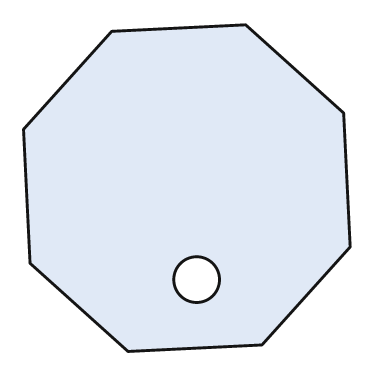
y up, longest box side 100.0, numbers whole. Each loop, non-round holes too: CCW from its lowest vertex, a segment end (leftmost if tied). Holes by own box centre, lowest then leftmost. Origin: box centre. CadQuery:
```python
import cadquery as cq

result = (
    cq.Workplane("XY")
    .moveTo(-18.0, -50.0)
    .lineTo(23.0, -48.0)
    .lineTo(50.0, -18.0)
    .lineTo(48.0, 23.0)
    .lineTo(18.0, 50.0)
    .lineTo(-23.0, 48.0)
    .lineTo(-50.0, 18.0)
    .lineTo(-48.0, -23.0)
    .close()
    .moveTo(3.0, -28.0)
    .circle(7.0)
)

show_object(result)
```